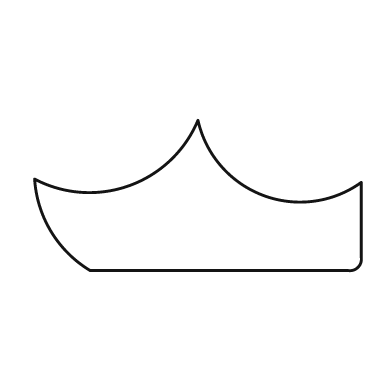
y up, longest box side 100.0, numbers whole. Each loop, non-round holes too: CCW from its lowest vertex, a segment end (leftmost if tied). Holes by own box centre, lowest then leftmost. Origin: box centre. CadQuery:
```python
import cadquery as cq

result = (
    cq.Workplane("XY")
    .moveTo(-33.0, -23.0)
    .lineTo(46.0, -23.0)
    .threePointArc((49.0, -22.0), (50.0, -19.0))
    .lineTo(50.0, 4.0)
    .threePointArc((20.0, 0.0), (0.0, 23.0))
    .threePointArc((-21.0, 3.0), (-50.0, 5.0))
    .threePointArc((-45.0, -11.0), (-33.0, -23.0))
    .close()
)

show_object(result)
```